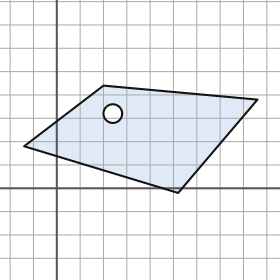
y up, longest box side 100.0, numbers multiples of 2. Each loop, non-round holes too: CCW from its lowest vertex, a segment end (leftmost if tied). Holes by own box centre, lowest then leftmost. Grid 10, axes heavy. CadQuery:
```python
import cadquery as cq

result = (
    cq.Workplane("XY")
    .moveTo(52.0, -2.0)
    .lineTo(86.0, 38.0)
    .lineTo(20.0, 44.0)
    .lineTo(-14.0, 18.0)
    .close()
    .moveTo(24.0, 32.0)
    .circle(4.0)
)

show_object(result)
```